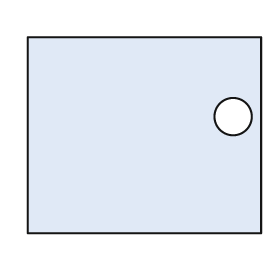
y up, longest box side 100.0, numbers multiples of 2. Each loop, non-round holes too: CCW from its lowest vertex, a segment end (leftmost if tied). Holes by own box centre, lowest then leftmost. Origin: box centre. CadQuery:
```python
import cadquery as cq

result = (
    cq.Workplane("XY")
    .moveTo(-50.0, -42.0)
    .lineTo(50.0, -42.0)
    .lineTo(50.0, 42.0)
    .lineTo(-50.0, 42.0)
    .close()
    .moveTo(38.0, 8.0)
    .circle(8.0)
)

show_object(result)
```